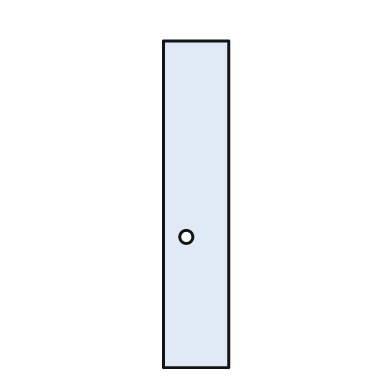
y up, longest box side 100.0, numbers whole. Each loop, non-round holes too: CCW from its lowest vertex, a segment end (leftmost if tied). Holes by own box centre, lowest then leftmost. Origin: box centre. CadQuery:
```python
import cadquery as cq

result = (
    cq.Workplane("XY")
    .moveTo(-10.0, -50.0)
    .lineTo(10.0, -50.0)
    .lineTo(10.0, 50.0)
    .lineTo(-10.0, 50.0)
    .close()
    .moveTo(-3.0, -10.0)
    .circle(2.0)
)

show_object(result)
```